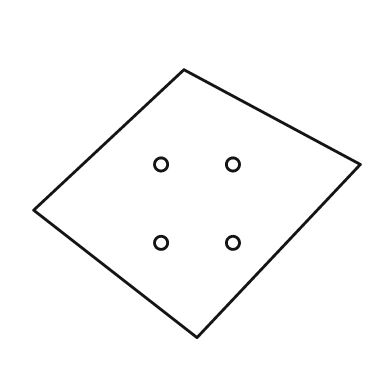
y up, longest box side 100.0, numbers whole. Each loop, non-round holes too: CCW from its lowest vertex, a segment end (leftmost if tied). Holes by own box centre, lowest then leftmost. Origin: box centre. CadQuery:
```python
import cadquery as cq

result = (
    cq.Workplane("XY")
    .moveTo(0.0, -41.0)
    .lineTo(50.0, 12.0)
    .lineTo(-4.0, 41.0)
    .lineTo(-50.0, -2.0)
    .close()
    .moveTo(-11.0, -12.0)
    .circle(2.0)
    .moveTo(11.0, -12.0)
    .circle(2.0)
    .moveTo(-11.0, 12.0)
    .circle(2.0)
    .moveTo(11.0, 12.0)
    .circle(2.0)
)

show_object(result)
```